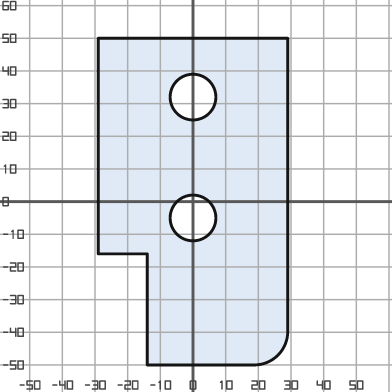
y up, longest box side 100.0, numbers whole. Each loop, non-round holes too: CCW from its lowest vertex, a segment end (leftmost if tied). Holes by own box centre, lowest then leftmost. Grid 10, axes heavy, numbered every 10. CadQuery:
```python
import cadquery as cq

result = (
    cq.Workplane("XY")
    .moveTo(-14.0, -50.0)
    .lineTo(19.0, -50.0)
    .threePointArc((26.0, -47.0), (29.0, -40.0))
    .lineTo(29.0, 50.0)
    .lineTo(-29.0, 50.0)
    .lineTo(-29.0, -16.0)
    .lineTo(-14.0, -16.0)
    .close()
    .moveTo(0.0, -5.0)
    .circle(7.0)
    .moveTo(0.0, 32.0)
    .circle(7.0)
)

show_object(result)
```